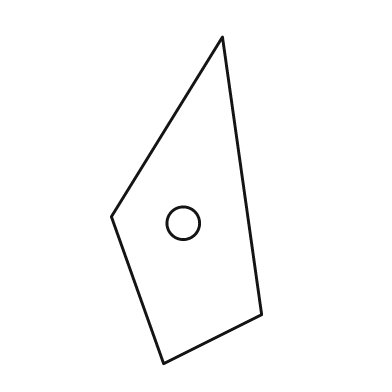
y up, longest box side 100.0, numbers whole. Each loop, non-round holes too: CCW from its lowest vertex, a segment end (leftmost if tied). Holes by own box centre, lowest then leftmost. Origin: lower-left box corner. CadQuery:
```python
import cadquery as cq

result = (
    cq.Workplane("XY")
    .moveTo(16.0, 0.0)
    .lineTo(46.0, 15.0)
    .lineTo(34.0, 100.0)
    .lineTo(0.0, 45.0)
    .close()
    .moveTo(22.0, 43.0)
    .circle(5.0)
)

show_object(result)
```